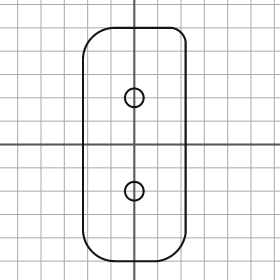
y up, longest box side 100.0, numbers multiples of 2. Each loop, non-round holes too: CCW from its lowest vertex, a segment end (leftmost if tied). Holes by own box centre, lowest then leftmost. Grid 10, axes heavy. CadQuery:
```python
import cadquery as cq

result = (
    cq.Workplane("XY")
    .moveTo(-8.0, -50.0)
    .lineTo(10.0, -50.0)
    .threePointArc((18.0, -46.0), (22.0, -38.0))
    .lineTo(22.0, 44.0)
    .threePointArc((20.0, 48.0), (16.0, 50.0))
    .lineTo(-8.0, 50.0)
    .threePointArc((-18.0, 46.0), (-22.0, 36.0))
    .lineTo(-22.0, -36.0)
    .threePointArc((-18.0, -46.0), (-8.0, -50.0))
    .close()
    .moveTo(0.0, -20.0)
    .circle(4.0)
    .moveTo(0.0, 20.0)
    .circle(4.0)
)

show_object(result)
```